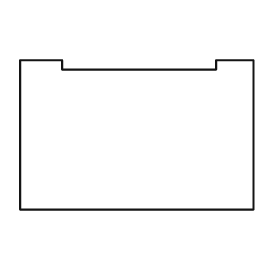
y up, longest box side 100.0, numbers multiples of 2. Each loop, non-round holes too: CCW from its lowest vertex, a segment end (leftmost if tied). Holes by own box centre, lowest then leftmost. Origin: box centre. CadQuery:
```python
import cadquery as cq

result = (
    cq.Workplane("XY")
    .moveTo(-50.0, -32.0)
    .lineTo(50.0, -32.0)
    .lineTo(50.0, 32.0)
    .lineTo(34.0, 32.0)
    .lineTo(34.0, 28.0)
    .lineTo(-32.0, 28.0)
    .lineTo(-32.0, 32.0)
    .lineTo(-50.0, 32.0)
    .close()
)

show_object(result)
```